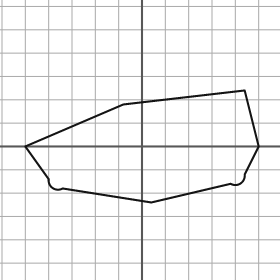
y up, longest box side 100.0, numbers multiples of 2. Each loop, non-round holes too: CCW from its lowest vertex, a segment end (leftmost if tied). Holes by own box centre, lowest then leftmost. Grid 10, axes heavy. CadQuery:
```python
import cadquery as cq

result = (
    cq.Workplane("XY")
    .moveTo(4.0, -24.0)
    .lineTo(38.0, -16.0)
    .threePointArc((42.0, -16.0), (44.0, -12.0))
    .lineTo(50.0, 0.0)
    .lineTo(44.0, 24.0)
    .lineTo(-8.0, 18.0)
    .lineTo(-50.0, 0.0)
    .lineTo(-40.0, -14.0)
    .threePointArc((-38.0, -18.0), (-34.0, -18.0))
    .close()
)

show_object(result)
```